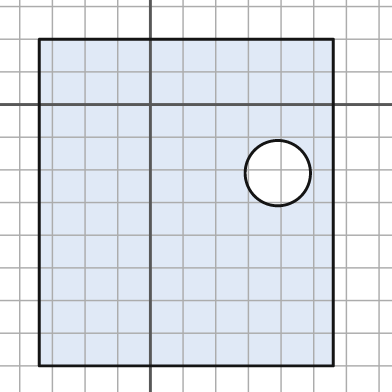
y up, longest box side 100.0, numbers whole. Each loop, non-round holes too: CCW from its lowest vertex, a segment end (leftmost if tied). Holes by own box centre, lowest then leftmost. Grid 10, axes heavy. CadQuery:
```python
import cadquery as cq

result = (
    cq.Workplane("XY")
    .moveTo(-34.0, -80.0)
    .lineTo(56.0, -80.0)
    .lineTo(56.0, 20.0)
    .lineTo(-34.0, 20.0)
    .close()
    .moveTo(39.0, -21.0)
    .circle(10.0)
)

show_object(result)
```